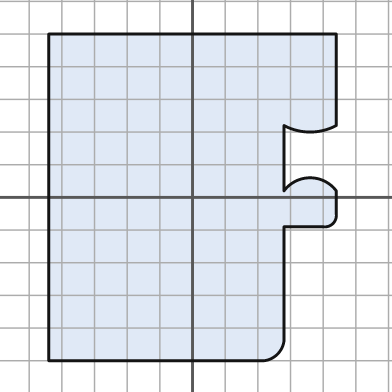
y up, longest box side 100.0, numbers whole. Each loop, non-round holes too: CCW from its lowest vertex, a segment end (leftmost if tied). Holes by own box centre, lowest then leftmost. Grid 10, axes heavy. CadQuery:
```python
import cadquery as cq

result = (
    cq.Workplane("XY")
    .moveTo(-44.0, -50.0)
    .lineTo(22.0, -50.0)
    .threePointArc((26.0, -48.0), (28.0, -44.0))
    .lineTo(28.0, -9.0)
    .lineTo(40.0, -9.0)
    .threePointArc((43.0, -8.0), (44.0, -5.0))
    .lineTo(44.0, 2.0)
    .threePointArc((36.0, 6.0), (28.0, 2.0))
    .lineTo(28.0, 22.0)
    .threePointArc((36.0, 20.0), (44.0, 22.0))
    .lineTo(44.0, 50.0)
    .lineTo(-44.0, 50.0)
    .close()
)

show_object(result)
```